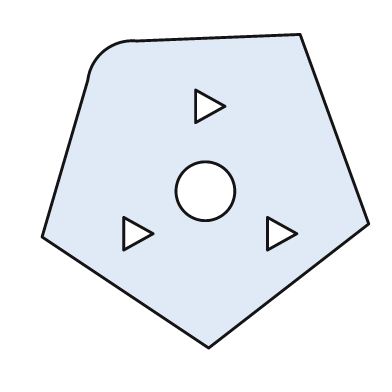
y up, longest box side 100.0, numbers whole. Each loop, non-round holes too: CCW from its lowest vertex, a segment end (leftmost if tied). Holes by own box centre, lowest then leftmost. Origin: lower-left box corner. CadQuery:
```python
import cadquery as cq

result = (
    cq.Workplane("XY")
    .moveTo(51.0, 0.0)
    .lineTo(100.0, 38.0)
    .lineTo(79.0, 96.0)
    .lineTo(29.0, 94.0)
    .threePointArc((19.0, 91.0), (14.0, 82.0))
    .lineTo(0.0, 34.0)
    .close()
    .moveTo(25.0, 30.0)
    .lineTo(34.0, 35.0)
    .lineTo(25.0, 40.0)
    .close()
    .moveTo(69.0, 30.0)
    .lineTo(78.0, 35.0)
    .lineTo(69.0, 40.0)
    .close()
    .moveTo(50.0, 48.0)
    .circle(9.0)
    .moveTo(47.0, 69.0)
    .lineTo(56.0, 74.0)
    .lineTo(47.0, 79.0)
    .close()
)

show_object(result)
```